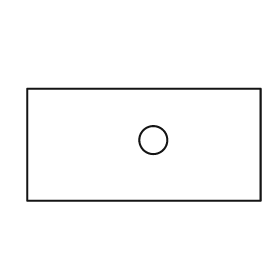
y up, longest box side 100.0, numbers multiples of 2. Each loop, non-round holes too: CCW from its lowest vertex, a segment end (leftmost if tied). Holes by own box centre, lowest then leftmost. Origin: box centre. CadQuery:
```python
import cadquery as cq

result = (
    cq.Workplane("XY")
    .moveTo(-50.0, -24.0)
    .lineTo(50.0, -24.0)
    .lineTo(50.0, 24.0)
    .lineTo(-50.0, 24.0)
    .close()
    .moveTo(4.0, 2.0)
    .circle(6.0)
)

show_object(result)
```